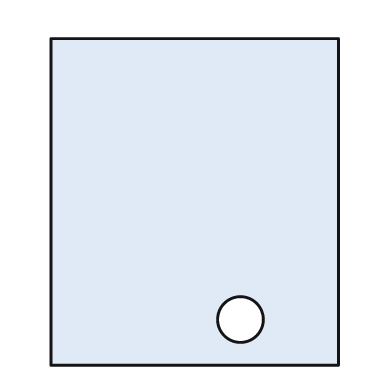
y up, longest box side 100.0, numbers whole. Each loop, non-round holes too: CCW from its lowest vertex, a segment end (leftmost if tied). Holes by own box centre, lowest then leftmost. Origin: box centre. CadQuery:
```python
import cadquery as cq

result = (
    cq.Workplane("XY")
    .moveTo(-44.0, -50.0)
    .lineTo(44.0, -50.0)
    .lineTo(44.0, 50.0)
    .lineTo(-44.0, 50.0)
    .close()
    .moveTo(14.0, -36.0)
    .circle(7.0)
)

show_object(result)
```